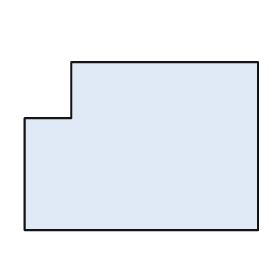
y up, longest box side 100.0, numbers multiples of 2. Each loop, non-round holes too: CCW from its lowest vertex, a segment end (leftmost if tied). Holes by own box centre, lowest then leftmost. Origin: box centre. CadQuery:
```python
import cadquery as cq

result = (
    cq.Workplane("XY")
    .moveTo(-50.0, -36.0)
    .lineTo(50.0, -36.0)
    .lineTo(50.0, 36.0)
    .lineTo(-30.0, 36.0)
    .lineTo(-30.0, 12.0)
    .lineTo(-50.0, 12.0)
    .close()
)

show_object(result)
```